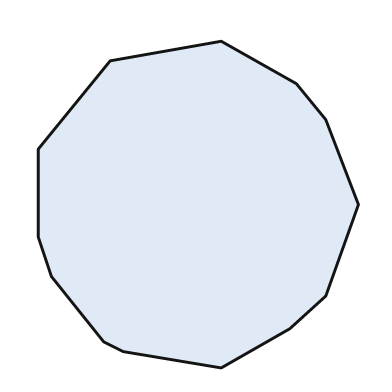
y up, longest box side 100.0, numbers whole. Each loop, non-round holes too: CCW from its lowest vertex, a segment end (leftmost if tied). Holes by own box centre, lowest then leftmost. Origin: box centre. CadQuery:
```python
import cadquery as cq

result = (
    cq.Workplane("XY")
    .moveTo(7.0, -50.0)
    .lineTo(28.0, -38.0)
    .lineTo(39.0, -28.0)
    .lineTo(49.0, 0.0)
    .lineTo(39.0, 26.0)
    .lineTo(30.0, 37.0)
    .lineTo(7.0, 50.0)
    .lineTo(-27.0, 44.0)
    .lineTo(-49.0, 17.0)
    .lineTo(-49.0, -10.0)
    .lineTo(-45.0, -22.0)
    .lineTo(-29.0, -42.0)
    .lineTo(-23.0, -45.0)
    .close()
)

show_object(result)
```